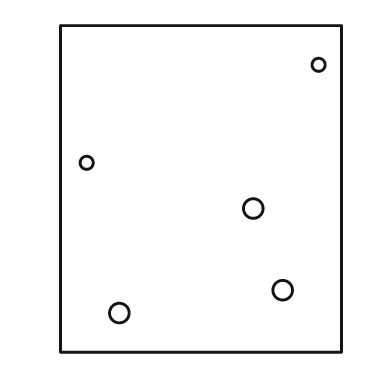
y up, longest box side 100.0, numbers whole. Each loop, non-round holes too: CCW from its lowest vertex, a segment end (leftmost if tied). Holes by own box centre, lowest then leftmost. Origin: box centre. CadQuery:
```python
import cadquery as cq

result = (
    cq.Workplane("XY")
    .moveTo(-43.0, -50.0)
    .lineTo(43.0, -50.0)
    .lineTo(43.0, 50.0)
    .lineTo(-43.0, 50.0)
    .close()
    .moveTo(-25.0, -38.0)
    .circle(3.0)
    .moveTo(25.0, -31.0)
    .circle(3.0)
    .moveTo(16.0, -6.0)
    .circle(3.0)
    .moveTo(-35.0, 8.0)
    .circle(2.0)
    .moveTo(36.0, 38.0)
    .circle(2.0)
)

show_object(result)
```